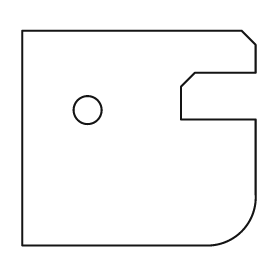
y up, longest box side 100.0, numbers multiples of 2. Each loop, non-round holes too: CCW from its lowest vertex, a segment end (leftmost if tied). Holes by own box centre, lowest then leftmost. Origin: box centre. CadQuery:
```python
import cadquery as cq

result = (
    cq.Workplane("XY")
    .moveTo(-50.0, -46.0)
    .lineTo(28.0, -46.0)
    .threePointArc((44.0, -40.0), (50.0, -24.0))
    .lineTo(50.0, 8.0)
    .lineTo(18.0, 8.0)
    .lineTo(18.0, 22.0)
    .lineTo(24.0, 28.0)
    .lineTo(50.0, 28.0)
    .lineTo(50.0, 40.0)
    .lineTo(44.0, 46.0)
    .lineTo(-50.0, 46.0)
    .close()
    .moveTo(-22.0, 12.0)
    .circle(6.0)
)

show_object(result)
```